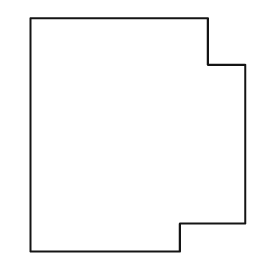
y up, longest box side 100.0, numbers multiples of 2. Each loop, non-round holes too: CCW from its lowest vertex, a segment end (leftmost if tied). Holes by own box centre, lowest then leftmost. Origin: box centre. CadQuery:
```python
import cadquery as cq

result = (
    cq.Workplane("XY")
    .moveTo(-46.0, -50.0)
    .lineTo(18.0, -50.0)
    .lineTo(18.0, -38.0)
    .lineTo(46.0, -38.0)
    .lineTo(46.0, 30.0)
    .lineTo(30.0, 30.0)
    .lineTo(30.0, 50.0)
    .lineTo(-46.0, 50.0)
    .close()
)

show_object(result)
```